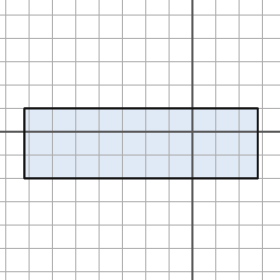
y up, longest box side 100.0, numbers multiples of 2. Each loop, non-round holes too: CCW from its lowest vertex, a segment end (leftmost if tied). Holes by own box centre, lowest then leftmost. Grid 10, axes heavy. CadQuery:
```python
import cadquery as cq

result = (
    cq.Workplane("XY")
    .moveTo(-72.0, -20.0)
    .lineTo(28.0, -20.0)
    .lineTo(28.0, 10.0)
    .lineTo(-72.0, 10.0)
    .close()
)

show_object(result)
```